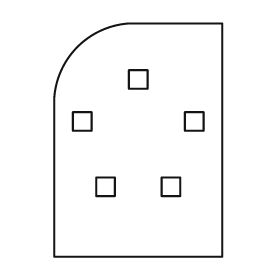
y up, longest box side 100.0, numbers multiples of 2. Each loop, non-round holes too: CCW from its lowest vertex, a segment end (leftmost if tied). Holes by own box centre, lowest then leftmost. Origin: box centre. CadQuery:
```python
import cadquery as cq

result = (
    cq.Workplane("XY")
    .moveTo(-36.0, -50.0)
    .lineTo(36.0, -50.0)
    .lineTo(36.0, 50.0)
    .lineTo(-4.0, 50.0)
    .threePointArc((-26.0, 40.0), (-36.0, 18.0))
    .close()
    .moveTo(-18.0, -24.0)
    .lineTo(-10.0, -24.0)
    .lineTo(-10.0, -16.0)
    .lineTo(-18.0, -16.0)
    .close()
    .moveTo(10.0, -24.0)
    .lineTo(18.0, -24.0)
    .lineTo(18.0, -16.0)
    .lineTo(10.0, -16.0)
    .close()
    .moveTo(-28.0, 4.0)
    .lineTo(-20.0, 4.0)
    .lineTo(-20.0, 12.0)
    .lineTo(-28.0, 12.0)
    .close()
    .moveTo(20.0, 4.0)
    .lineTo(28.0, 4.0)
    .lineTo(28.0, 12.0)
    .lineTo(20.0, 12.0)
    .close()
    .moveTo(-4.0, 22.0)
    .lineTo(4.0, 22.0)
    .lineTo(4.0, 30.0)
    .lineTo(-4.0, 30.0)
    .close()
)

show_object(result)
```